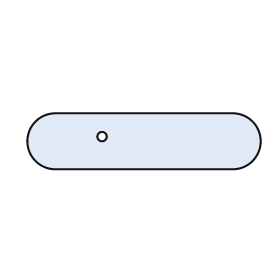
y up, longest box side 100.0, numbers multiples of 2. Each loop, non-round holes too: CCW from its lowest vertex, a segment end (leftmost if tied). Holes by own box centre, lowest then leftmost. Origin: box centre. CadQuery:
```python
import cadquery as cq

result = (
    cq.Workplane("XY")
    .moveTo(-38.0, -12.0)
    .lineTo(38.0, -12.0)
    .threePointArc((50.0, 0.0), (38.0, 12.0))
    .lineTo(-38.0, 12.0)
    .threePointArc((-50.0, 0.0), (-38.0, -12.0))
    .close()
    .moveTo(-18.0, 2.0)
    .circle(2.0)
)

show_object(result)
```